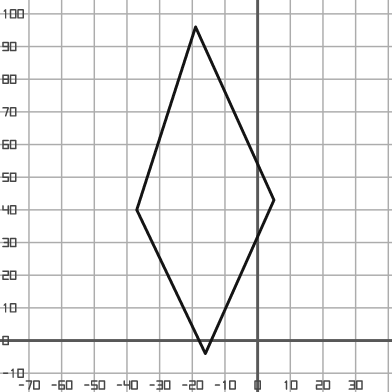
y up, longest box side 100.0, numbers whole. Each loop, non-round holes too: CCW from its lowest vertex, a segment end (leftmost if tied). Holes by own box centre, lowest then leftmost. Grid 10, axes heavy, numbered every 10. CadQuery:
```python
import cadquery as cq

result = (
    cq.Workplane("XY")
    .moveTo(-16.0, -4.0)
    .lineTo(5.0, 43.0)
    .lineTo(-19.0, 96.0)
    .lineTo(-37.0, 40.0)
    .close()
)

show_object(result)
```